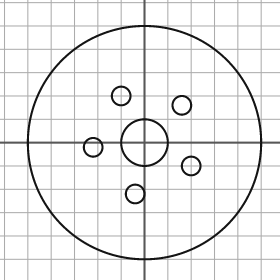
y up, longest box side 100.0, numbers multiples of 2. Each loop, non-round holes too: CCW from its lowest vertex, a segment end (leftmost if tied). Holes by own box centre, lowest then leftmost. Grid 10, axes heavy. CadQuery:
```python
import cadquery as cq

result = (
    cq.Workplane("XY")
    .moveTo(0.0, 0.0)
    .circle(50.0)
    .moveTo(-4.0, -22.0)
    .circle(4.0)
    .moveTo(20.0, -10.0)
    .circle(4.0)
    .moveTo(-22.0, -2.0)
    .circle(4.0)
    .moveTo(0.0, 0.0)
    .circle(10.0)
    .moveTo(16.0, 16.0)
    .circle(4.0)
    .moveTo(-10.0, 20.0)
    .circle(4.0)
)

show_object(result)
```